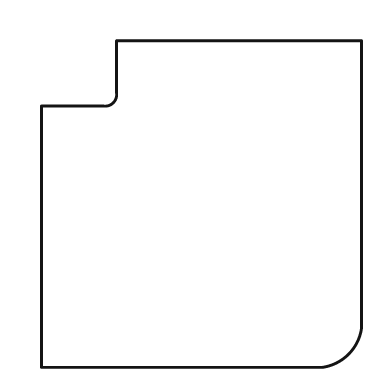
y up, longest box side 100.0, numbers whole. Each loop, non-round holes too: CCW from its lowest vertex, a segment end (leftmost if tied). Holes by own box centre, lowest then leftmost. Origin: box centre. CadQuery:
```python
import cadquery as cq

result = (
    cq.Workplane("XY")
    .moveTo(-49.0, -50.0)
    .lineTo(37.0, -50.0)
    .threePointArc((45.0, -46.0), (49.0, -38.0))
    .lineTo(49.0, 50.0)
    .lineTo(-26.0, 50.0)
    .lineTo(-26.0, 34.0)
    .threePointArc((-27.0, 31.0), (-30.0, 30.0))
    .lineTo(-49.0, 30.0)
    .close()
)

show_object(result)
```